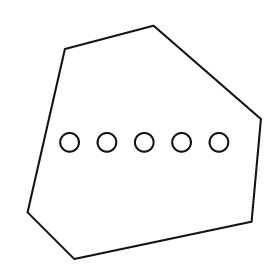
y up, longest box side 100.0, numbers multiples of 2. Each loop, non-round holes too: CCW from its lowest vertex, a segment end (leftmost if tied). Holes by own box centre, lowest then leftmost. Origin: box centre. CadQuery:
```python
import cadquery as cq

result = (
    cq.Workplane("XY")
    .moveTo(-30.0, -50.0)
    .lineTo(46.0, -34.0)
    .lineTo(50.0, 10.0)
    .lineTo(4.0, 50.0)
    .lineTo(-34.0, 40.0)
    .lineTo(-50.0, -30.0)
    .close()
    .moveTo(-32.0, 0.0)
    .circle(4.0)
    .moveTo(-16.0, 0.0)
    .circle(4.0)
    .moveTo(0.0, 0.0)
    .circle(4.0)
    .moveTo(16.0, 0.0)
    .circle(4.0)
    .moveTo(32.0, 0.0)
    .circle(4.0)
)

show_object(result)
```